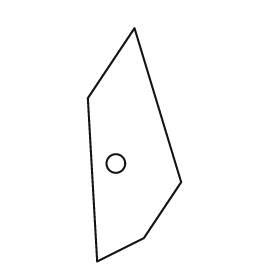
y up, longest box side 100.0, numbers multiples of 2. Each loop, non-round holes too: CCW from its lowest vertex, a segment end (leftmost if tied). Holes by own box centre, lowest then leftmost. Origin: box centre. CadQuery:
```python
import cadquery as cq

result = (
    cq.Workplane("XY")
    .moveTo(-16.0, -50.0)
    .lineTo(4.0, -40.0)
    .lineTo(20.0, -16.0)
    .lineTo(0.0, 50.0)
    .lineTo(-20.0, 20.0)
    .close()
    .moveTo(-8.0, -8.0)
    .circle(4.0)
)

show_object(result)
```